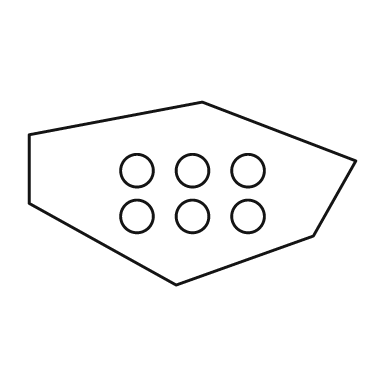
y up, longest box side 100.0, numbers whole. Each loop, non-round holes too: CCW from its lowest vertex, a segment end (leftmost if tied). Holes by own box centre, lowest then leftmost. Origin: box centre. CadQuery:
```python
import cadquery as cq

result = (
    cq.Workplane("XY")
    .moveTo(-5.0, -28.0)
    .lineTo(37.0, -13.0)
    .lineTo(50.0, 10.0)
    .lineTo(3.0, 28.0)
    .lineTo(-50.0, 18.0)
    .lineTo(-50.0, -3.0)
    .close()
    .moveTo(-17.0, -7.0)
    .circle(5.0)
    .moveTo(0.0, -7.0)
    .circle(5.0)
    .moveTo(17.0, -7.0)
    .circle(5.0)
    .moveTo(-17.0, 7.0)
    .circle(5.0)
    .moveTo(0.0, 7.0)
    .circle(5.0)
    .moveTo(17.0, 7.0)
    .circle(5.0)
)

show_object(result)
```